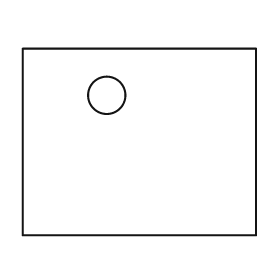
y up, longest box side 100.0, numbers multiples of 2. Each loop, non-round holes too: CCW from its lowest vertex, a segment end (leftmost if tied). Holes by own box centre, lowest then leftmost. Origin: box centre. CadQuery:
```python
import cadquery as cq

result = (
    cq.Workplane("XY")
    .moveTo(-50.0, -40.0)
    .lineTo(50.0, -40.0)
    .lineTo(50.0, 40.0)
    .lineTo(-50.0, 40.0)
    .close()
    .moveTo(-14.0, 20.0)
    .circle(8.0)
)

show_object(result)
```